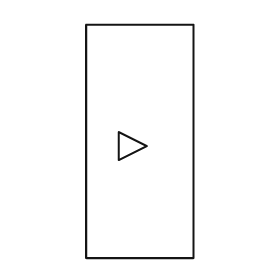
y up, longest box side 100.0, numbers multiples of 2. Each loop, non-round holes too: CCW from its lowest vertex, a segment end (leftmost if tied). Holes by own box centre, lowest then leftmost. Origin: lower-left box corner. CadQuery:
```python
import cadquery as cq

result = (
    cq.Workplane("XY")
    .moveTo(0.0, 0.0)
    .lineTo(46.0, 0.0)
    .lineTo(46.0, 100.0)
    .lineTo(0.0, 100.0)
    .close()
    .moveTo(14.0, 42.0)
    .lineTo(26.0, 48.0)
    .lineTo(14.0, 54.0)
    .close()
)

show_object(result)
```